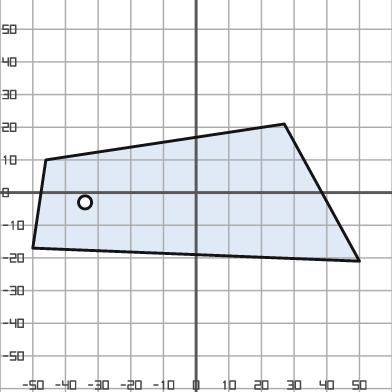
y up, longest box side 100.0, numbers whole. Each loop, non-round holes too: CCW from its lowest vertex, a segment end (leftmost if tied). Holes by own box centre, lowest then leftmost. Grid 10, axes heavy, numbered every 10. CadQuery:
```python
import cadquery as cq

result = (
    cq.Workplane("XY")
    .moveTo(50.0, -21.0)
    .lineTo(27.0, 21.0)
    .lineTo(-46.0, 10.0)
    .lineTo(-50.0, -17.0)
    .close()
    .moveTo(-34.0, -3.0)
    .circle(2.0)
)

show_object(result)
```